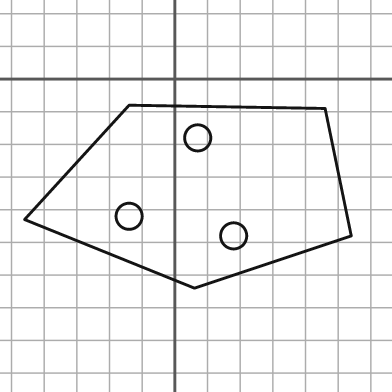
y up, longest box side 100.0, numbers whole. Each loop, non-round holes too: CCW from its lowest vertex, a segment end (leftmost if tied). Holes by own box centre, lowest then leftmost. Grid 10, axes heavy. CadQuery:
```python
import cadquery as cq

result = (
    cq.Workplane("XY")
    .moveTo(6.0, -64.0)
    .lineTo(54.0, -48.0)
    .lineTo(46.0, -9.0)
    .lineTo(-14.0, -8.0)
    .lineTo(-46.0, -43.0)
    .close()
    .moveTo(18.0, -48.0)
    .circle(4.0)
    .moveTo(-14.0, -42.0)
    .circle(4.0)
    .moveTo(7.0, -18.0)
    .circle(4.0)
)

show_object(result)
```